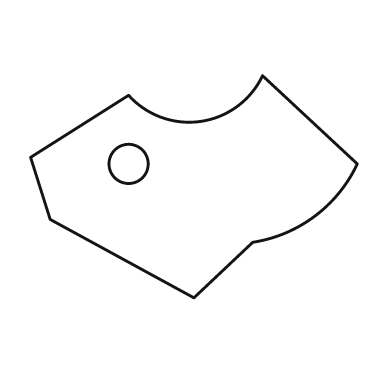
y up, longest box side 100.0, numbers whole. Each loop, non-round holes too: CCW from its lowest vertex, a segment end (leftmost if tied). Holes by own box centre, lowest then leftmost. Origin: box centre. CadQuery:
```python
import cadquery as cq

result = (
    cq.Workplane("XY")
    .moveTo(0.0, -34.0)
    .lineTo(18.0, -17.0)
    .threePointArc((37.0, -9.0), (50.0, 7.0))
    .lineTo(21.0, 34.0)
    .threePointArc((2.0, 20.0), (-20.0, 28.0))
    .lineTo(-50.0, 9.0)
    .lineTo(-44.0, -10.0)
    .close()
    .moveTo(-20.0, 7.0)
    .circle(6.0)
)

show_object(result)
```